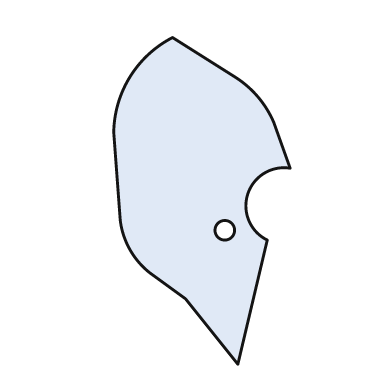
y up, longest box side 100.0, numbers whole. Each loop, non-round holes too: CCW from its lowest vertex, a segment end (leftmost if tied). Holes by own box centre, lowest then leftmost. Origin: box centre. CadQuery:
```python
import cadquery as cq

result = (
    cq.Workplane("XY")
    .moveTo(11.0, -50.0)
    .lineTo(20.0, -12.0)
    .threePointArc((14.0, 2.0), (27.0, 10.0))
    .lineTo(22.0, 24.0)
    .threePointArc((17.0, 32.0), (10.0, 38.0))
    .lineTo(-9.0, 50.0)
    .threePointArc((-22.0, 38.0), (-27.0, 21.0))
    .lineTo(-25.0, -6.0)
    .threePointArc((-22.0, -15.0), (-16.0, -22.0))
    .lineTo(-5.0, -30.0)
    .close()
    .moveTo(7.0, -9.0)
    .circle(3.0)
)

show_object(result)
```